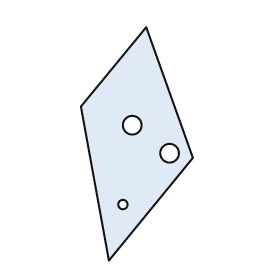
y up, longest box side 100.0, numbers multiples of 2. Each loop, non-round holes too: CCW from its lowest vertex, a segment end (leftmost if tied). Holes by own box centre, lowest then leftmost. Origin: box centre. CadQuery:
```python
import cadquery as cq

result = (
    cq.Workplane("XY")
    .moveTo(-12.0, -50.0)
    .lineTo(24.0, -6.0)
    .lineTo(4.0, 50.0)
    .lineTo(-24.0, 16.0)
    .close()
    .moveTo(-6.0, -26.0)
    .circle(2.0)
    .moveTo(14.0, -4.0)
    .circle(4.0)
    .moveTo(-2.0, 8.0)
    .circle(4.0)
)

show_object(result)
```